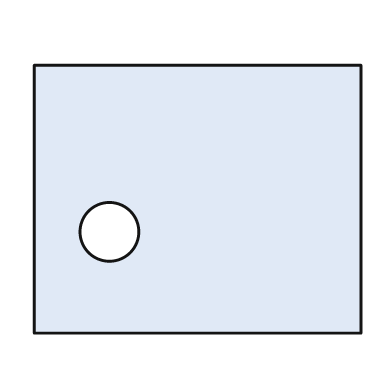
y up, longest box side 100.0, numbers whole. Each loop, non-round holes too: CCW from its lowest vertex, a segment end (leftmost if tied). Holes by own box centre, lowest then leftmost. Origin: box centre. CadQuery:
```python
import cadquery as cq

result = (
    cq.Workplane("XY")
    .moveTo(-50.0, -41.0)
    .lineTo(50.0, -41.0)
    .lineTo(50.0, 41.0)
    .lineTo(-50.0, 41.0)
    .close()
    .moveTo(-27.0, -10.0)
    .circle(9.0)
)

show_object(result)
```